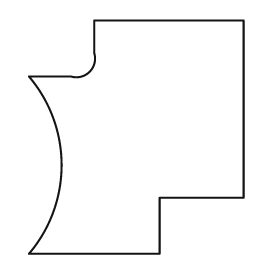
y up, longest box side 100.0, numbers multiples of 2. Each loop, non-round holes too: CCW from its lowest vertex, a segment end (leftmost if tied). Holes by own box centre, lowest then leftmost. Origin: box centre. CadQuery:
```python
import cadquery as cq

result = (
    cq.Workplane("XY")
    .moveTo(-46.0, -50.0)
    .lineTo(10.0, -50.0)
    .lineTo(10.0, -26.0)
    .lineTo(46.0, -26.0)
    .lineTo(46.0, 50.0)
    .lineTo(-18.0, 50.0)
    .lineTo(-18.0, 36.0)
    .threePointArc((-20.0, 28.0), (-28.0, 26.0))
    .lineTo(-46.0, 26.0)
    .threePointArc((-32.0, -12.0), (-46.0, -50.0))
    .close()
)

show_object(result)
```